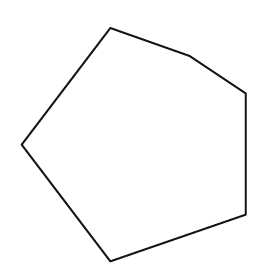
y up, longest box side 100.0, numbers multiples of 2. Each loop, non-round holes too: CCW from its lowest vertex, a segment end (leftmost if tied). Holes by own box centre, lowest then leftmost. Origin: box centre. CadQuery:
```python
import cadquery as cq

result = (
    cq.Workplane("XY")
    .moveTo(-10.0, -50.0)
    .lineTo(48.0, -30.0)
    .lineTo(48.0, 22.0)
    .lineTo(24.0, 38.0)
    .lineTo(-10.0, 50.0)
    .lineTo(-48.0, 0.0)
    .close()
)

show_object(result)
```